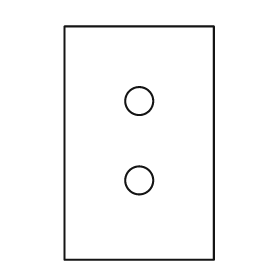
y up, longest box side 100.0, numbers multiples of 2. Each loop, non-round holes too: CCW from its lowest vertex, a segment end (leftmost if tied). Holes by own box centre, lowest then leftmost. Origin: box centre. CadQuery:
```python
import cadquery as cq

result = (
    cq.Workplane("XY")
    .moveTo(-32.0, -50.0)
    .lineTo(32.0, -50.0)
    .lineTo(32.0, 50.0)
    .lineTo(-32.0, 50.0)
    .close()
    .moveTo(0.0, -16.0)
    .circle(6.0)
    .moveTo(0.0, 18.0)
    .circle(6.0)
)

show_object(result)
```